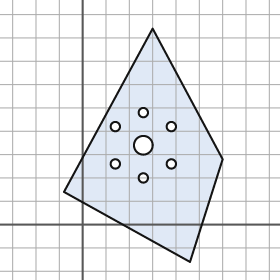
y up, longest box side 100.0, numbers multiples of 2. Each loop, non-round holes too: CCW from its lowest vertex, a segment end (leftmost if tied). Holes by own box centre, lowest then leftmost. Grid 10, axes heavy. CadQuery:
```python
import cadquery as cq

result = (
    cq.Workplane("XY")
    .moveTo(46.0, -16.0)
    .lineTo(60.0, 28.0)
    .lineTo(30.0, 84.0)
    .lineTo(-8.0, 14.0)
    .close()
    .moveTo(26.0, 20.0)
    .circle(2.0)
    .moveTo(14.0, 26.0)
    .circle(2.0)
    .moveTo(38.0, 26.0)
    .circle(2.0)
    .moveTo(26.0, 34.0)
    .circle(4.0)
    .moveTo(14.0, 42.0)
    .circle(2.0)
    .moveTo(38.0, 42.0)
    .circle(2.0)
    .moveTo(26.0, 48.0)
    .circle(2.0)
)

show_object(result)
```